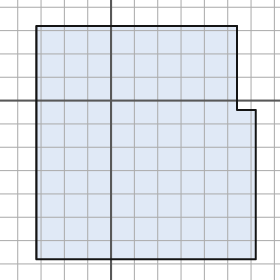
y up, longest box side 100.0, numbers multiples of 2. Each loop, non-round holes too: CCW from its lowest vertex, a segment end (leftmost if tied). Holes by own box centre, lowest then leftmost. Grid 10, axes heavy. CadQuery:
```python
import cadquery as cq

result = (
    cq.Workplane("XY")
    .moveTo(-32.0, -68.0)
    .lineTo(62.0, -68.0)
    .lineTo(62.0, -4.0)
    .lineTo(54.0, -4.0)
    .lineTo(54.0, 32.0)
    .lineTo(-32.0, 32.0)
    .close()
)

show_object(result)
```